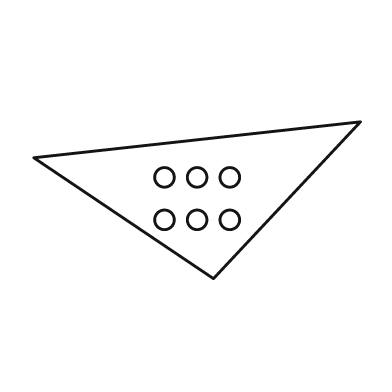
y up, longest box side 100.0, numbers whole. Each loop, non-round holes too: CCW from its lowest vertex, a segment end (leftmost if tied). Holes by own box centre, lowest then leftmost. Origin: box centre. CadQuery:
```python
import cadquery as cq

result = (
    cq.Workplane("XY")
    .moveTo(5.0, -24.0)
    .lineTo(50.0, 24.0)
    .lineTo(-50.0, 13.0)
    .close()
    .moveTo(-10.0, -6.0)
    .circle(3.0)
    .moveTo(0.0, -6.0)
    .circle(3.0)
    .moveTo(10.0, -6.0)
    .circle(3.0)
    .moveTo(-10.0, 7.0)
    .circle(3.0)
    .moveTo(0.0, 7.0)
    .circle(3.0)
    .moveTo(10.0, 7.0)
    .circle(3.0)
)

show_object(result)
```